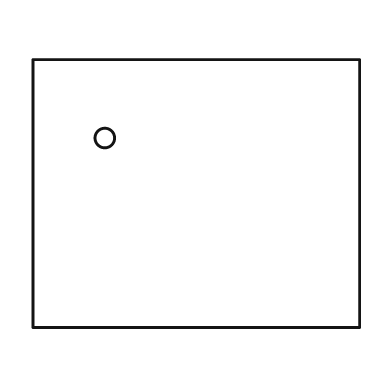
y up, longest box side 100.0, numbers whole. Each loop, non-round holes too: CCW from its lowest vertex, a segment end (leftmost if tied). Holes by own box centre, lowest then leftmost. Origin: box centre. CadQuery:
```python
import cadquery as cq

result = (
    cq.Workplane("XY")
    .moveTo(-50.0, -41.0)
    .lineTo(50.0, -41.0)
    .lineTo(50.0, 41.0)
    .lineTo(-50.0, 41.0)
    .close()
    .moveTo(-28.0, 17.0)
    .circle(3.0)
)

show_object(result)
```